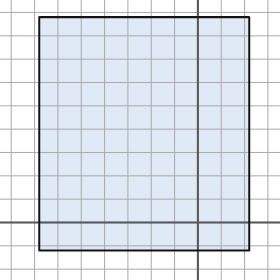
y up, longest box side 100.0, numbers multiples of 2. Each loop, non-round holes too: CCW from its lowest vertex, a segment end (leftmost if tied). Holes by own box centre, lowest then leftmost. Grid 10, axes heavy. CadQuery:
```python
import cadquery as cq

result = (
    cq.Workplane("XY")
    .moveTo(-68.0, -12.0)
    .lineTo(22.0, -12.0)
    .lineTo(22.0, 88.0)
    .lineTo(-68.0, 88.0)
    .close()
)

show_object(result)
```